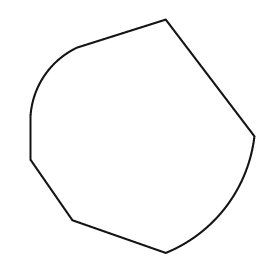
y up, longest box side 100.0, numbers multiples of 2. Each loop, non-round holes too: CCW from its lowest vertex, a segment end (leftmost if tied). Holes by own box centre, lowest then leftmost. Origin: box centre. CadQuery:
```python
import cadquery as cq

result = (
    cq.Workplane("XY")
    .moveTo(10.0, -50.0)
    .threePointArc((36.0, -30.0), (48.0, 0.0))
    .lineTo(10.0, 50.0)
    .lineTo(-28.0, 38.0)
    .threePointArc((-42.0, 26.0), (-48.0, 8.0))
    .lineTo(-48.0, -10.0)
    .lineTo(-30.0, -36.0)
    .close()
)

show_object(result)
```